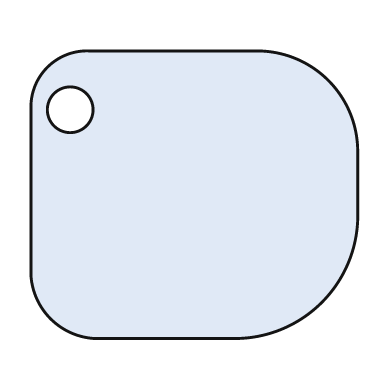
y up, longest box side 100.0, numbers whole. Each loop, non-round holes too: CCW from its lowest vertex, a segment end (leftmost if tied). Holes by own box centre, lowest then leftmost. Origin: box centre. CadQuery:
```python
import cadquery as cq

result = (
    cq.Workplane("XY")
    .moveTo(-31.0, -44.0)
    .lineTo(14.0, -44.0)
    .threePointArc((39.0, -33.0), (50.0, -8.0))
    .lineTo(50.0, 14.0)
    .threePointArc((41.0, 35.0), (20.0, 44.0))
    .lineTo(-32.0, 44.0)
    .threePointArc((-45.0, 39.0), (-50.0, 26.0))
    .lineTo(-50.0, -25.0)
    .threePointArc((-44.0, -38.0), (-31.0, -44.0))
    .close()
    .moveTo(-38.0, 26.0)
    .circle(7.0)
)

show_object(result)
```